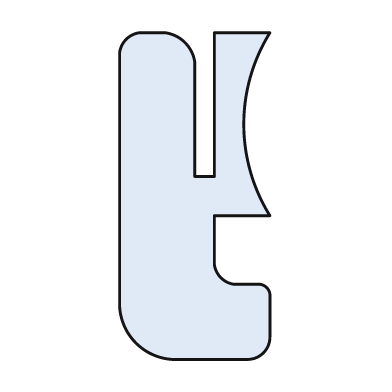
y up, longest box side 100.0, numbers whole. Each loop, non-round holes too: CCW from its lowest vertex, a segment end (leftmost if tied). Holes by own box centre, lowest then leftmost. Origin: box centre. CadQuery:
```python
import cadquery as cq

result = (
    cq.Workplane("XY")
    .moveTo(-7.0, -50.0)
    .lineTo(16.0, -50.0)
    .threePointArc((21.0, -48.0), (23.0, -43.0))
    .lineTo(23.0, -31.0)
    .threePointArc((22.0, -28.0), (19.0, -27.0))
    .lineTo(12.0, -27.0)
    .threePointArc((8.0, -25.0), (6.0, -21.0))
    .lineTo(6.0, -6.0)
    .lineTo(23.0, -6.0)
    .threePointArc((15.0, 22.0), (23.0, 50.0))
    .lineTo(6.0, 50.0)
    .lineTo(6.0, 6.0)
    .lineTo(0.0, 6.0)
    .lineTo(0.0, 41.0)
    .threePointArc((-3.0, 47.0), (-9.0, 50.0))
    .lineTo(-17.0, 50.0)
    .threePointArc((-21.0, 48.0), (-23.0, 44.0))
    .lineTo(-23.0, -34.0)
    .threePointArc((-18.0, -45.0), (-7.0, -50.0))
    .close()
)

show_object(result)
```